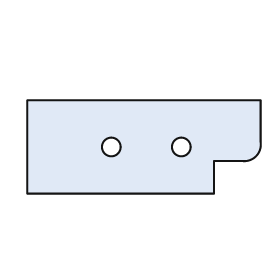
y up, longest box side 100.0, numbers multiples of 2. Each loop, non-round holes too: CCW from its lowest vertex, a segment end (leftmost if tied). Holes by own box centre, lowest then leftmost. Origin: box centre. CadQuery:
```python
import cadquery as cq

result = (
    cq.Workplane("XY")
    .moveTo(-50.0, -20.0)
    .lineTo(30.0, -20.0)
    .lineTo(30.0, -6.0)
    .lineTo(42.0, -6.0)
    .threePointArc((48.0, -4.0), (50.0, 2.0))
    .lineTo(50.0, 20.0)
    .lineTo(-50.0, 20.0)
    .close()
    .moveTo(-14.0, 0.0)
    .circle(4.0)
    .moveTo(16.0, 0.0)
    .circle(4.0)
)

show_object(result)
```